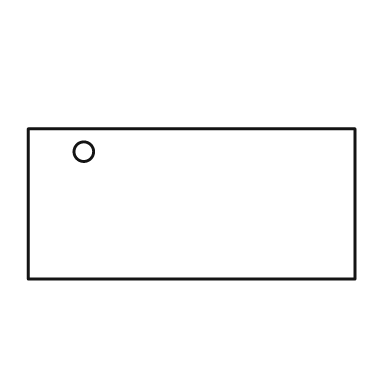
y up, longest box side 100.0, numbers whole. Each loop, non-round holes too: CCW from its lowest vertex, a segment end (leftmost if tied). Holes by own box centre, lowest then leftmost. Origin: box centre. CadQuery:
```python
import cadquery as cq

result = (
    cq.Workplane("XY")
    .moveTo(-50.0, -23.0)
    .lineTo(50.0, -23.0)
    .lineTo(50.0, 23.0)
    .lineTo(-50.0, 23.0)
    .close()
    .moveTo(-33.0, 16.0)
    .circle(3.0)
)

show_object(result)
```